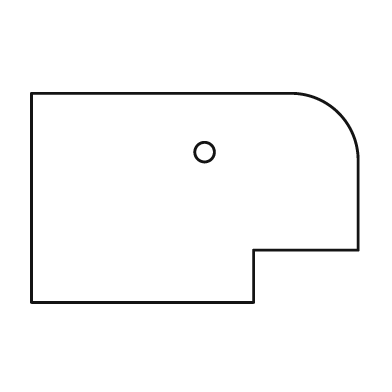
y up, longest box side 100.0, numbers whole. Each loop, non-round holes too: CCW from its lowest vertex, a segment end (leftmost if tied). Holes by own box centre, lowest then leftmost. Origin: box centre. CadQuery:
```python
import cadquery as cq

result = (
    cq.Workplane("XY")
    .moveTo(-50.0, -32.0)
    .lineTo(18.0, -32.0)
    .lineTo(18.0, -16.0)
    .lineTo(50.0, -16.0)
    .lineTo(50.0, 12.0)
    .threePointArc((44.0, 26.0), (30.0, 32.0))
    .lineTo(-50.0, 32.0)
    .close()
    .moveTo(3.0, 14.0)
    .circle(3.0)
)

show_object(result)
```